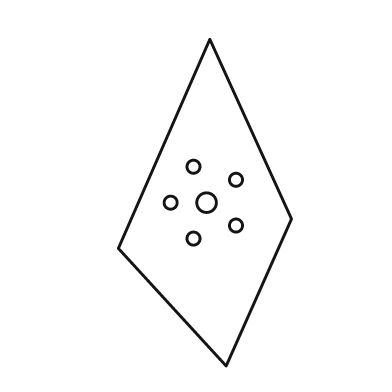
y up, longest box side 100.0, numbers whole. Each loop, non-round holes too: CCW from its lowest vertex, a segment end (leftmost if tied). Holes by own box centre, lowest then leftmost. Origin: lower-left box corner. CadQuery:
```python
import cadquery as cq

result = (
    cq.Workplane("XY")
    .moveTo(33.0, 0.0)
    .lineTo(53.0, 45.0)
    .lineTo(28.0, 100.0)
    .lineTo(0.0, 36.0)
    .close()
    .moveTo(23.0, 39.0)
    .circle(2.0)
    .moveTo(36.0, 43.0)
    .circle(2.0)
    .moveTo(16.0, 50.0)
    .circle(2.0)
    .moveTo(27.0, 50.0)
    .circle(3.0)
    .moveTo(36.0, 57.0)
    .circle(2.0)
    .moveTo(23.0, 61.0)
    .circle(2.0)
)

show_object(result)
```